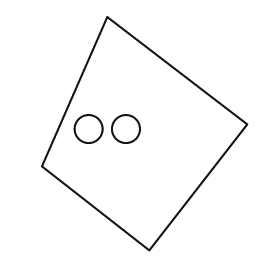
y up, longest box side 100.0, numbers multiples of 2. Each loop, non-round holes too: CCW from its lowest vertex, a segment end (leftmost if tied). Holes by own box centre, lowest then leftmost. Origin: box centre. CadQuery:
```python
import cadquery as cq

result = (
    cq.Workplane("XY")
    .moveTo(2.0, -50.0)
    .lineTo(44.0, 4.0)
    .lineTo(-16.0, 50.0)
    .lineTo(-44.0, -14.0)
    .close()
    .moveTo(-24.0, 2.0)
    .circle(6.0)
    .moveTo(-8.0, 2.0)
    .circle(6.0)
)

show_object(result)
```